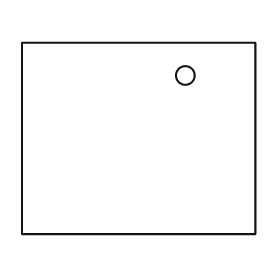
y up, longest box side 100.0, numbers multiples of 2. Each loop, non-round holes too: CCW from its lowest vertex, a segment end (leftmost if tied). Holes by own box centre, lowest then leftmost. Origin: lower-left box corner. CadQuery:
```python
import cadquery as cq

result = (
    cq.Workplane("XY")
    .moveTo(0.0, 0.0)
    .lineTo(100.0, 0.0)
    .lineTo(100.0, 82.0)
    .lineTo(0.0, 82.0)
    .close()
    .moveTo(70.0, 68.0)
    .circle(4.0)
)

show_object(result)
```